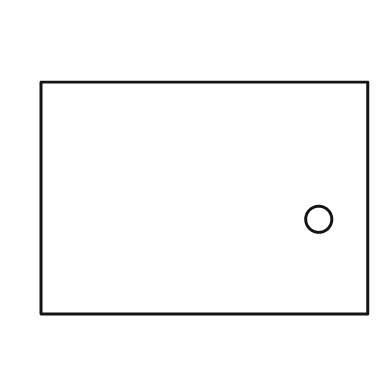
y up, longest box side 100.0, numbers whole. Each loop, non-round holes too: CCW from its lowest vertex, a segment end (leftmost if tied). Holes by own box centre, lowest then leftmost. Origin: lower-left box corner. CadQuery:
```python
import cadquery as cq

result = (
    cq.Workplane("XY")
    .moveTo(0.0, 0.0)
    .lineTo(100.0, 0.0)
    .lineTo(100.0, 71.0)
    .lineTo(0.0, 71.0)
    .close()
    .moveTo(85.0, 29.0)
    .circle(4.0)
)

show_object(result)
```